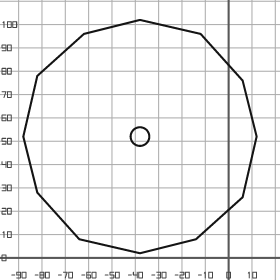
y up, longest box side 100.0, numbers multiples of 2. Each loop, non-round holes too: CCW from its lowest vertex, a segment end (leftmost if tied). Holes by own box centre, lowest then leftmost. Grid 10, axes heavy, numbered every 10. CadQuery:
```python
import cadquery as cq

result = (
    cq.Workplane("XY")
    .moveTo(-38.0, 2.0)
    .lineTo(-14.0, 8.0)
    .lineTo(6.0, 26.0)
    .lineTo(12.0, 52.0)
    .lineTo(6.0, 76.0)
    .lineTo(-12.0, 96.0)
    .lineTo(-38.0, 102.0)
    .lineTo(-62.0, 96.0)
    .lineTo(-82.0, 78.0)
    .lineTo(-88.0, 52.0)
    .lineTo(-82.0, 28.0)
    .lineTo(-64.0, 8.0)
    .close()
    .moveTo(-38.0, 52.0)
    .circle(4.0)
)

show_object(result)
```